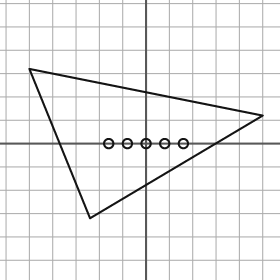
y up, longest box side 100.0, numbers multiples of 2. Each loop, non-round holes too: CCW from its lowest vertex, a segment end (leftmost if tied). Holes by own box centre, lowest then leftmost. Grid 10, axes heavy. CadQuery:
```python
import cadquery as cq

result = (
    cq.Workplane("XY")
    .moveTo(-24.0, -32.0)
    .lineTo(50.0, 12.0)
    .lineTo(-50.0, 32.0)
    .close()
    .moveTo(-16.0, 0.0)
    .circle(2.0)
    .moveTo(-8.0, 0.0)
    .circle(2.0)
    .moveTo(0.0, 0.0)
    .circle(2.0)
    .moveTo(8.0, 0.0)
    .circle(2.0)
    .moveTo(16.0, 0.0)
    .circle(2.0)
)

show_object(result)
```